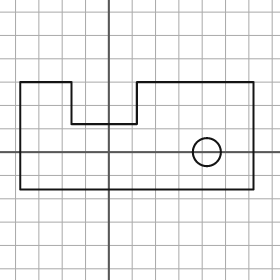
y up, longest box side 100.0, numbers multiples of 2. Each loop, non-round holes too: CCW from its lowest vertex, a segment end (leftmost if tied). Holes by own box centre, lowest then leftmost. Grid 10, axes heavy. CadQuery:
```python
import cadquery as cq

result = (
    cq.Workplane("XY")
    .moveTo(-38.0, -16.0)
    .lineTo(62.0, -16.0)
    .lineTo(62.0, 30.0)
    .lineTo(12.0, 30.0)
    .lineTo(12.0, 12.0)
    .lineTo(-16.0, 12.0)
    .lineTo(-16.0, 30.0)
    .lineTo(-38.0, 30.0)
    .close()
    .moveTo(42.0, 0.0)
    .circle(6.0)
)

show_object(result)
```